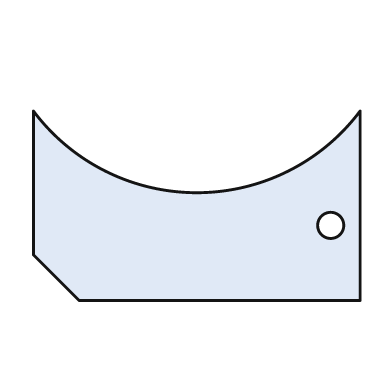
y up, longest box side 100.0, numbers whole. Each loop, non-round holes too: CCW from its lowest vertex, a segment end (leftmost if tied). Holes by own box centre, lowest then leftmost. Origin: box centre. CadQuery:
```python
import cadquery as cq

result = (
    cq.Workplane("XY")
    .moveTo(-36.0, -29.0)
    .lineTo(50.0, -29.0)
    .lineTo(50.0, 29.0)
    .threePointArc((0.0, 4.0), (-50.0, 29.0))
    .lineTo(-50.0, -15.0)
    .close()
    .moveTo(41.0, -6.0)
    .circle(4.0)
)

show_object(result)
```